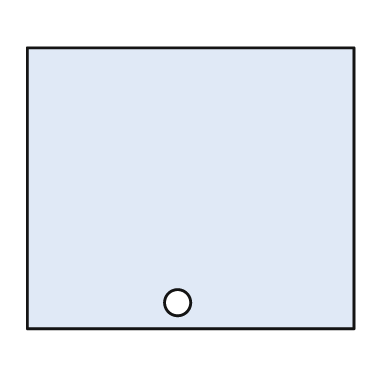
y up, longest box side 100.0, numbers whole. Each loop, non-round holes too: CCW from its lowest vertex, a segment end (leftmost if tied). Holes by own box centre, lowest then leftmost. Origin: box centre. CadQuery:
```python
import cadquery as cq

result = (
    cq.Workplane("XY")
    .moveTo(-50.0, -43.0)
    .lineTo(50.0, -43.0)
    .lineTo(50.0, 43.0)
    .lineTo(-50.0, 43.0)
    .close()
    .moveTo(-4.0, -35.0)
    .circle(4.0)
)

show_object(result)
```